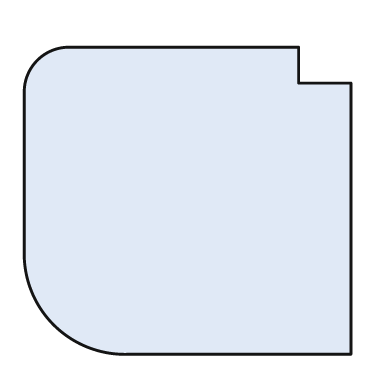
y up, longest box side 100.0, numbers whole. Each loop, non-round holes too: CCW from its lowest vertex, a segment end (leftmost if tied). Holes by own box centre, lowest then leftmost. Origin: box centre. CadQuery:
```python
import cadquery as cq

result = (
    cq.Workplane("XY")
    .moveTo(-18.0, -47.0)
    .lineTo(50.0, -47.0)
    .lineTo(50.0, 36.0)
    .lineTo(34.0, 36.0)
    .lineTo(34.0, 47.0)
    .lineTo(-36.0, 47.0)
    .threePointArc((-46.0, 43.0), (-50.0, 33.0))
    .lineTo(-50.0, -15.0)
    .threePointArc((-41.0, -38.0), (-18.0, -47.0))
    .close()
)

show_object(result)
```